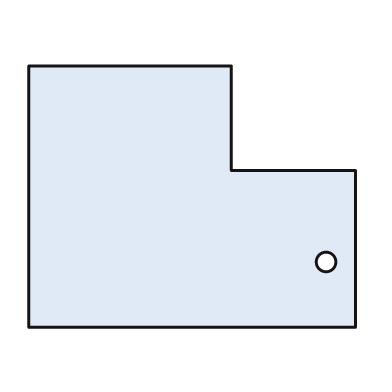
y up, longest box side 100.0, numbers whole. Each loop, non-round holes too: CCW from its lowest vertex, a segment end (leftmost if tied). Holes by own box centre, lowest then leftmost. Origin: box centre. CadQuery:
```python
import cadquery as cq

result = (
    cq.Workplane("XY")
    .moveTo(-50.0, -40.0)
    .lineTo(50.0, -40.0)
    .lineTo(50.0, 8.0)
    .lineTo(12.0, 8.0)
    .lineTo(12.0, 40.0)
    .lineTo(-50.0, 40.0)
    .close()
    .moveTo(41.0, -20.0)
    .circle(3.0)
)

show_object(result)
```